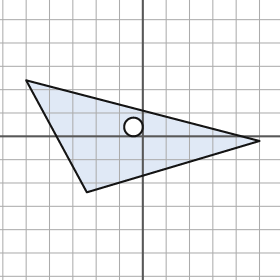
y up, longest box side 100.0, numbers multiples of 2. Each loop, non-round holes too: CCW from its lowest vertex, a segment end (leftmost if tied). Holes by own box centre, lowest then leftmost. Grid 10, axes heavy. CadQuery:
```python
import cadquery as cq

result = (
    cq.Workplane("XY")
    .moveTo(-24.0, -24.0)
    .lineTo(50.0, -2.0)
    .lineTo(-50.0, 24.0)
    .close()
    .moveTo(-4.0, 4.0)
    .circle(4.0)
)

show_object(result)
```